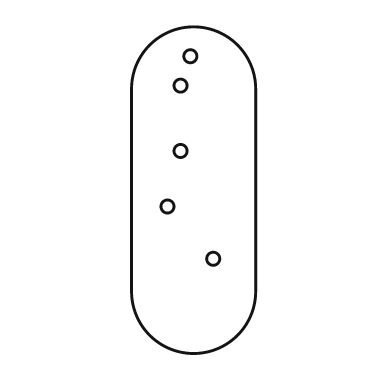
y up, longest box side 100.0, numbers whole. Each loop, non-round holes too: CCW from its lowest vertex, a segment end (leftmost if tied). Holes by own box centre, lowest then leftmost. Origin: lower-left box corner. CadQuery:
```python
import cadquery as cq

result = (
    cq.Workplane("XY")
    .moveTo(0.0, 19.0)
    .threePointArc((19.0, 0.0), (38.0, 19.0))
    .lineTo(38.0, 81.0)
    .threePointArc((19.0, 100.0), (0.0, 81.0))
    .close()
    .moveTo(25.0, 29.0)
    .circle(2.0)
    .moveTo(11.0, 45.0)
    .circle(2.0)
    .moveTo(15.0, 62.0)
    .circle(2.0)
    .moveTo(15.0, 82.0)
    .circle(2.0)
    .moveTo(18.0, 91.0)
    .circle(2.0)
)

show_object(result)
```